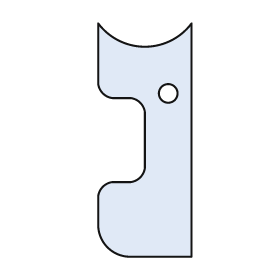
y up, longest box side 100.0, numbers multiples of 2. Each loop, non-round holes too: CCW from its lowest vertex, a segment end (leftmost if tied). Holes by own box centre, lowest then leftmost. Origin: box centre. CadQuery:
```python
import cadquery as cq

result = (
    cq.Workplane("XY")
    .moveTo(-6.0, -50.0)
    .lineTo(20.0, -50.0)
    .lineTo(20.0, 50.0)
    .threePointArc((0.0, 40.0), (-20.0, 50.0))
    .lineTo(-20.0, 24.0)
    .threePointArc((-18.0, 20.0), (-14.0, 18.0))
    .lineTo(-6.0, 18.0)
    .threePointArc((-2.0, 16.0), (0.0, 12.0))
    .lineTo(0.0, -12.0)
    .threePointArc((-2.0, -16.0), (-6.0, -18.0))
    .lineTo(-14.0, -18.0)
    .threePointArc((-18.0, -20.0), (-20.0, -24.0))
    .lineTo(-20.0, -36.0)
    .threePointArc((-16.0, -46.0), (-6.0, -50.0))
    .close()
    .moveTo(10.0, 20.0)
    .circle(4.0)
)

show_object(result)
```